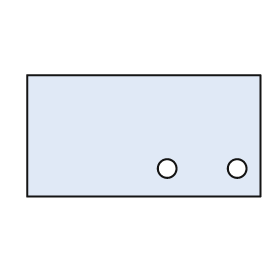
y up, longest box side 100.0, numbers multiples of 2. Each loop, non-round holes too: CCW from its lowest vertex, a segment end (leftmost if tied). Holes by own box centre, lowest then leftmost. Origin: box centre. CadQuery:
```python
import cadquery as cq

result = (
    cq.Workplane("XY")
    .moveTo(-50.0, -26.0)
    .lineTo(50.0, -26.0)
    .lineTo(50.0, 26.0)
    .lineTo(-50.0, 26.0)
    .close()
    .moveTo(10.0, -14.0)
    .circle(4.0)
    .moveTo(40.0, -14.0)
    .circle(4.0)
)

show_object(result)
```